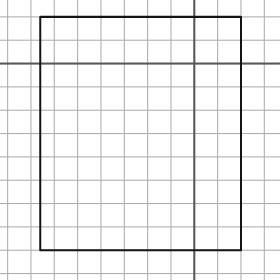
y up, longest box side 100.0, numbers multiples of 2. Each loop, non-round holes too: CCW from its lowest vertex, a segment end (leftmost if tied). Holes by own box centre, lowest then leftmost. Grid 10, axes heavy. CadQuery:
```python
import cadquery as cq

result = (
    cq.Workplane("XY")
    .moveTo(-66.0, -80.0)
    .lineTo(20.0, -80.0)
    .lineTo(20.0, 20.0)
    .lineTo(-66.0, 20.0)
    .close()
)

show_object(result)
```